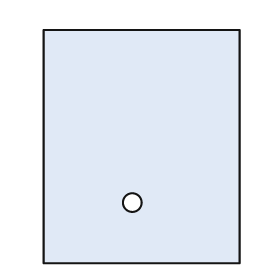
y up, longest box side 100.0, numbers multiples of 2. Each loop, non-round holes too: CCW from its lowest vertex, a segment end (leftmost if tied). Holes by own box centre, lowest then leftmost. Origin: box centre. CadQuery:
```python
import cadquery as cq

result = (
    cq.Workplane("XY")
    .moveTo(-42.0, -50.0)
    .lineTo(42.0, -50.0)
    .lineTo(42.0, 50.0)
    .lineTo(-42.0, 50.0)
    .close()
    .moveTo(-4.0, -24.0)
    .circle(4.0)
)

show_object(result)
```